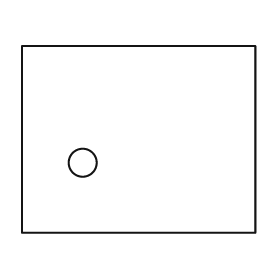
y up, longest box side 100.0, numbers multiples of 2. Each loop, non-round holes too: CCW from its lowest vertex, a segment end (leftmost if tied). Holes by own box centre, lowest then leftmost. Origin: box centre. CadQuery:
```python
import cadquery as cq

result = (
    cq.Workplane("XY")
    .moveTo(-50.0, -40.0)
    .lineTo(50.0, -40.0)
    .lineTo(50.0, 40.0)
    .lineTo(-50.0, 40.0)
    .close()
    .moveTo(-24.0, -10.0)
    .circle(6.0)
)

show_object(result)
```